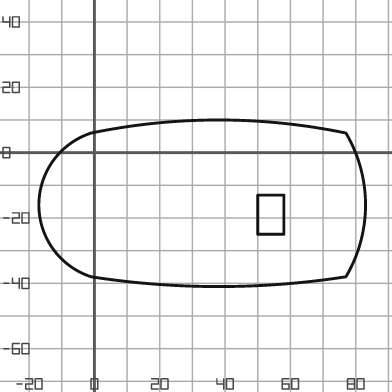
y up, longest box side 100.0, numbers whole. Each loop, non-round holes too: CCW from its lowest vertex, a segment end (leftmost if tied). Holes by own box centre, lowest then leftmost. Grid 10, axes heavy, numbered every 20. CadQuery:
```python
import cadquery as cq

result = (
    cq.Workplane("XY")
    .moveTo(-1.0, -38.0)
    .threePointArc((38.0, -41.0), (77.0, -38.0))
    .threePointArc((83.0, -16.0), (77.0, 6.0))
    .threePointArc((38.0, 10.0), (-1.0, 6.0))
    .threePointArc((-17.0, -16.0), (-1.0, -38.0))
    .close()
    .moveTo(50.0, -25.0)
    .lineTo(58.0, -25.0)
    .lineTo(58.0, -13.0)
    .lineTo(50.0, -13.0)
    .close()
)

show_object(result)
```